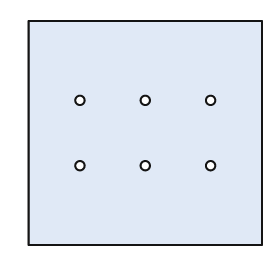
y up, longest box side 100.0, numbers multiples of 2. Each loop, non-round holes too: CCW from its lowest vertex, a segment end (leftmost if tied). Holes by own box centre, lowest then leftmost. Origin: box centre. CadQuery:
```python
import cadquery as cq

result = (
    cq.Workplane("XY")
    .moveTo(-50.0, -48.0)
    .lineTo(50.0, -48.0)
    .lineTo(50.0, 48.0)
    .lineTo(-50.0, 48.0)
    .close()
    .moveTo(-28.0, -14.0)
    .circle(2.0)
    .moveTo(0.0, -14.0)
    .circle(2.0)
    .moveTo(28.0, -14.0)
    .circle(2.0)
    .moveTo(-28.0, 14.0)
    .circle(2.0)
    .moveTo(0.0, 14.0)
    .circle(2.0)
    .moveTo(28.0, 14.0)
    .circle(2.0)
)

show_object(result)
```